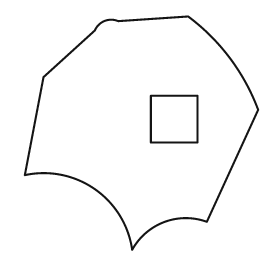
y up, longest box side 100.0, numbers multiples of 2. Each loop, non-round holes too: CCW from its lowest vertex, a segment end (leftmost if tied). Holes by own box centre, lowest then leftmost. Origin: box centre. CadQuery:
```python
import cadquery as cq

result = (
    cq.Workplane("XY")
    .moveTo(-4.0, -50.0)
    .threePointArc((10.0, -38.0), (28.0, -38.0))
    .lineTo(50.0, 10.0)
    .threePointArc((38.0, 32.0), (20.0, 50.0))
    .lineTo(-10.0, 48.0)
    .threePointArc((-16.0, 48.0), (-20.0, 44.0))
    .lineTo(-42.0, 24.0)
    .lineTo(-50.0, -18.0)
    .threePointArc((-20.0, -24.0), (-4.0, -50.0))
    .close()
    .moveTo(4.0, -4.0)
    .lineTo(24.0, -4.0)
    .lineTo(24.0, 16.0)
    .lineTo(4.0, 16.0)
    .close()
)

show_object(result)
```